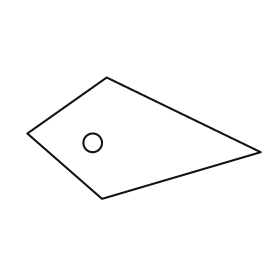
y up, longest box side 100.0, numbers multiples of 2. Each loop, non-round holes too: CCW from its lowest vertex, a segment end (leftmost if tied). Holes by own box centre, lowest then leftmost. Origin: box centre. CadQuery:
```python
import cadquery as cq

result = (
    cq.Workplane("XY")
    .moveTo(-18.0, -26.0)
    .lineTo(50.0, -6.0)
    .lineTo(-16.0, 26.0)
    .lineTo(-50.0, 2.0)
    .close()
    .moveTo(-22.0, -2.0)
    .circle(4.0)
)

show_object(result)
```